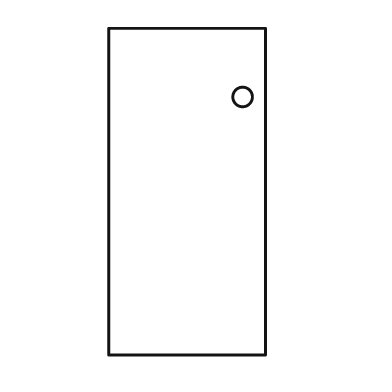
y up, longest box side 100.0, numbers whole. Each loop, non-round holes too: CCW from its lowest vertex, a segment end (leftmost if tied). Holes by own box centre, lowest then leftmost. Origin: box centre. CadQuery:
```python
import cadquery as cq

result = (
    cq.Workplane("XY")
    .moveTo(-24.0, -50.0)
    .lineTo(24.0, -50.0)
    .lineTo(24.0, 50.0)
    .lineTo(-24.0, 50.0)
    .close()
    .moveTo(17.0, 29.0)
    .circle(3.0)
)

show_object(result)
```